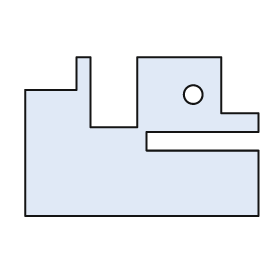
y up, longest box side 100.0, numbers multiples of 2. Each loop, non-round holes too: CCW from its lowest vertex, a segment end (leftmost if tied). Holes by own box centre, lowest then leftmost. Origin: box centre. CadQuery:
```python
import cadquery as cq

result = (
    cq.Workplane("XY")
    .moveTo(-50.0, -34.0)
    .lineTo(50.0, -34.0)
    .lineTo(50.0, -6.0)
    .lineTo(2.0, -6.0)
    .lineTo(2.0, 2.0)
    .lineTo(50.0, 2.0)
    .lineTo(50.0, 10.0)
    .lineTo(34.0, 10.0)
    .lineTo(34.0, 34.0)
    .lineTo(-2.0, 34.0)
    .lineTo(-2.0, 4.0)
    .lineTo(-22.0, 4.0)
    .lineTo(-22.0, 34.0)
    .lineTo(-28.0, 34.0)
    .lineTo(-28.0, 20.0)
    .lineTo(-50.0, 20.0)
    .close()
    .moveTo(22.0, 18.0)
    .circle(4.0)
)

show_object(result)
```